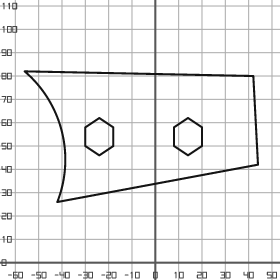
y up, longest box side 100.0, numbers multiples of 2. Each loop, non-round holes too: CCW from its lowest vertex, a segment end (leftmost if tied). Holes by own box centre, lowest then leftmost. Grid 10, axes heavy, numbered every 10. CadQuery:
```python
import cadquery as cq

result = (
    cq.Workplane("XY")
    .moveTo(-42.0, 26.0)
    .lineTo(44.0, 42.0)
    .lineTo(42.0, 80.0)
    .lineTo(-56.0, 82.0)
    .threePointArc((-40.0, 56.0), (-42.0, 26.0))
    .close()
    .moveTo(-24.0, 46.0)
    .lineTo(-18.0, 50.0)
    .lineTo(-18.0, 58.0)
    .lineTo(-24.0, 62.0)
    .lineTo(-30.0, 58.0)
    .lineTo(-30.0, 50.0)
    .close()
    .moveTo(14.0, 46.0)
    .lineTo(20.0, 50.0)
    .lineTo(20.0, 58.0)
    .lineTo(14.0, 62.0)
    .lineTo(8.0, 58.0)
    .lineTo(8.0, 50.0)
    .close()
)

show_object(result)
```